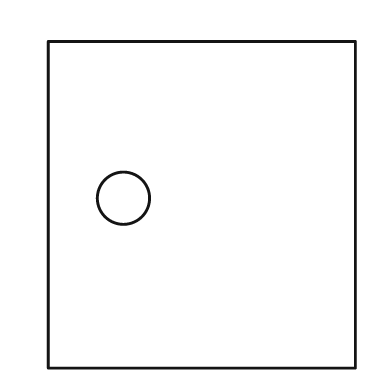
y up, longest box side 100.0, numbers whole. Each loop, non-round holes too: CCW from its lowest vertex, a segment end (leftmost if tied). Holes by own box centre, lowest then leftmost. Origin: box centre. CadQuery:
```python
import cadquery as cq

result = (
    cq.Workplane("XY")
    .moveTo(-47.0, -50.0)
    .lineTo(47.0, -50.0)
    .lineTo(47.0, 50.0)
    .lineTo(-47.0, 50.0)
    .close()
    .moveTo(-24.0, 2.0)
    .circle(8.0)
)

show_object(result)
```